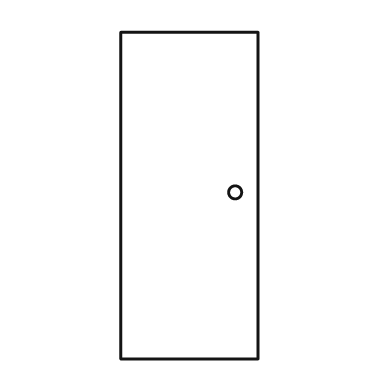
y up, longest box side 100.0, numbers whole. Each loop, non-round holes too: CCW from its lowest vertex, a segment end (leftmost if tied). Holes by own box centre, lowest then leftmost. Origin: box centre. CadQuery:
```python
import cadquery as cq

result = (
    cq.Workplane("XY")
    .moveTo(-21.0, -50.0)
    .lineTo(21.0, -50.0)
    .lineTo(21.0, 50.0)
    .lineTo(-21.0, 50.0)
    .close()
    .moveTo(14.0, 1.0)
    .circle(2.0)
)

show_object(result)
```